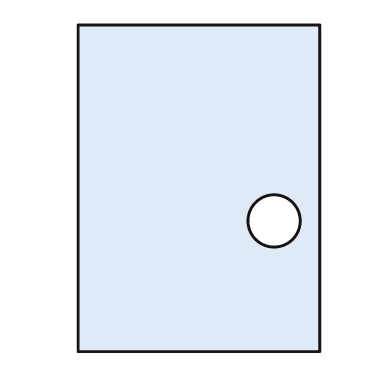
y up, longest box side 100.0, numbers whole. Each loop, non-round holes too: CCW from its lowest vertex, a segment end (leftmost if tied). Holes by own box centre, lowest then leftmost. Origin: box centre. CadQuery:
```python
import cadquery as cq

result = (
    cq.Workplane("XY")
    .moveTo(-37.0, -50.0)
    .lineTo(37.0, -50.0)
    .lineTo(37.0, 50.0)
    .lineTo(-37.0, 50.0)
    .close()
    .moveTo(23.0, -10.0)
    .circle(8.0)
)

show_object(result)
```